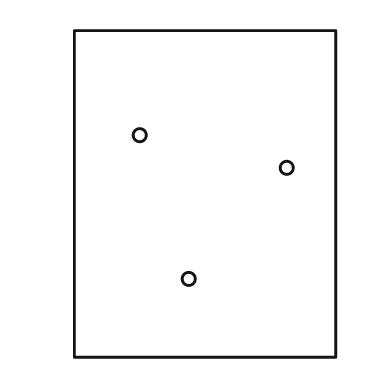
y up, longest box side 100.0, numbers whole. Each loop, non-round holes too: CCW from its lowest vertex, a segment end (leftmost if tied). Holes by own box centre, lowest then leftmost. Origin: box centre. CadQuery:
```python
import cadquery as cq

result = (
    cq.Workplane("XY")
    .moveTo(-40.0, -50.0)
    .lineTo(40.0, -50.0)
    .lineTo(40.0, 50.0)
    .lineTo(-40.0, 50.0)
    .close()
    .moveTo(-5.0, -26.0)
    .circle(2.0)
    .moveTo(25.0, 8.0)
    .circle(2.0)
    .moveTo(-20.0, 18.0)
    .circle(2.0)
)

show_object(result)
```